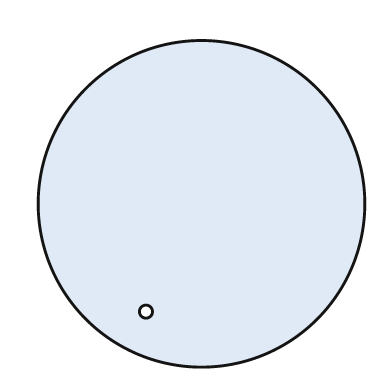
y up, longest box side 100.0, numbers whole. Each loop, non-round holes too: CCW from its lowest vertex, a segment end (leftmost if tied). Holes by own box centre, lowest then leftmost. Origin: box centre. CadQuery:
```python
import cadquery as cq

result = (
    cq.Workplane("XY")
    .moveTo(0.0, 0.0)
    .circle(50.0)
    .moveTo(-17.0, -33.0)
    .circle(2.0)
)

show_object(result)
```